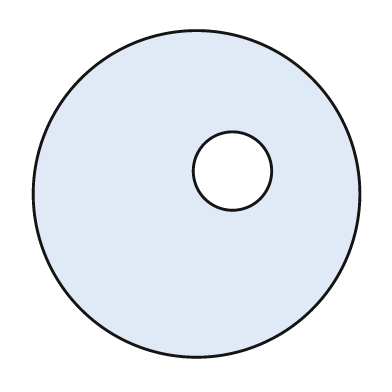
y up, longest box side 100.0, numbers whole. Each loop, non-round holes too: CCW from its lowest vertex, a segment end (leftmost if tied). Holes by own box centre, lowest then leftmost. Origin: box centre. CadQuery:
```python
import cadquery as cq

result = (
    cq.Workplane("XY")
    .moveTo(0.0, 0.0)
    .circle(50.0)
    .moveTo(11.0, 7.0)
    .circle(12.0)
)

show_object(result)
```